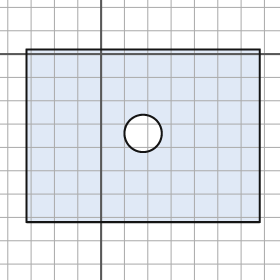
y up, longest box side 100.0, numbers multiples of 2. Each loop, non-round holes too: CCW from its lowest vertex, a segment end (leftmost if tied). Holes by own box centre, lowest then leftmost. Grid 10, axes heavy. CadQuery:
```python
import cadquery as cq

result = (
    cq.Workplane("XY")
    .moveTo(-32.0, -72.0)
    .lineTo(68.0, -72.0)
    .lineTo(68.0, 2.0)
    .lineTo(-32.0, 2.0)
    .close()
    .moveTo(18.0, -34.0)
    .circle(8.0)
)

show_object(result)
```